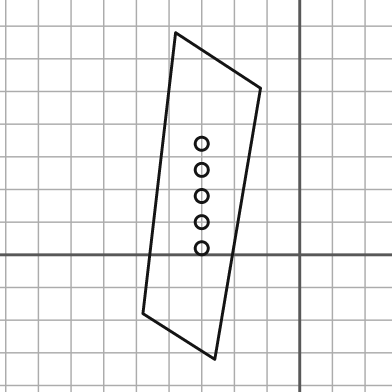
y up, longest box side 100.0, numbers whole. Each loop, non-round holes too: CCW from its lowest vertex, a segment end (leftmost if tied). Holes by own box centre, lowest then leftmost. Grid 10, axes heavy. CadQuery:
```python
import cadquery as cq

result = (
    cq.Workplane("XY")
    .moveTo(-26.0, -32.0)
    .lineTo(-12.0, 51.0)
    .lineTo(-38.0, 68.0)
    .lineTo(-48.0, -18.0)
    .close()
    .moveTo(-30.0, 2.0)
    .circle(2.0)
    .moveTo(-30.0, 10.0)
    .circle(2.0)
    .moveTo(-30.0, 18.0)
    .circle(2.0)
    .moveTo(-30.0, 26.0)
    .circle(2.0)
    .moveTo(-30.0, 34.0)
    .circle(2.0)
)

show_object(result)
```